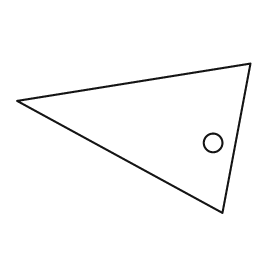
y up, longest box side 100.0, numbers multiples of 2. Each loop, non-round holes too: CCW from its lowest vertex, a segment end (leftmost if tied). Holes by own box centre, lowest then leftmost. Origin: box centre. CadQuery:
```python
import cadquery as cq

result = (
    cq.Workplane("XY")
    .moveTo(38.0, -32.0)
    .lineTo(50.0, 32.0)
    .lineTo(-50.0, 16.0)
    .close()
    .moveTo(34.0, -2.0)
    .circle(4.0)
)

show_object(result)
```